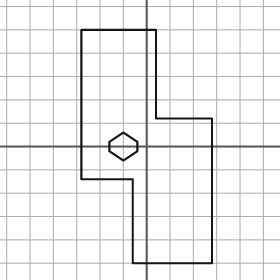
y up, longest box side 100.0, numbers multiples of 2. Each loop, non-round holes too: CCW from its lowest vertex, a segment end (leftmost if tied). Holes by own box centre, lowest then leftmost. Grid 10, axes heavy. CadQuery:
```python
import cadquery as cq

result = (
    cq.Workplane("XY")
    .moveTo(-6.0, -50.0)
    .lineTo(28.0, -50.0)
    .lineTo(28.0, 12.0)
    .lineTo(4.0, 12.0)
    .lineTo(4.0, 50.0)
    .lineTo(-28.0, 50.0)
    .lineTo(-28.0, -14.0)
    .lineTo(-6.0, -14.0)
    .close()
    .moveTo(-10.0, -6.0)
    .lineTo(-4.0, -2.0)
    .lineTo(-4.0, 2.0)
    .lineTo(-10.0, 6.0)
    .lineTo(-16.0, 2.0)
    .lineTo(-16.0, -2.0)
    .close()
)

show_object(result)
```